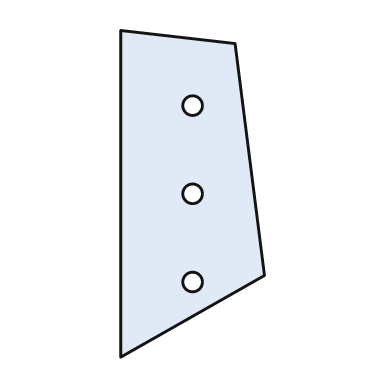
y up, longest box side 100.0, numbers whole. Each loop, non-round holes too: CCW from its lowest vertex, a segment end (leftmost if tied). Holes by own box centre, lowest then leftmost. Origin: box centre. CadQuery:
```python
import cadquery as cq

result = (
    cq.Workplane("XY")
    .moveTo(-22.0, -50.0)
    .lineTo(22.0, -25.0)
    .lineTo(13.0, 46.0)
    .lineTo(-22.0, 50.0)
    .close()
    .moveTo(0.0, -27.0)
    .circle(3.0)
    .moveTo(0.0, 0.0)
    .circle(3.0)
    .moveTo(0.0, 27.0)
    .circle(3.0)
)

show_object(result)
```